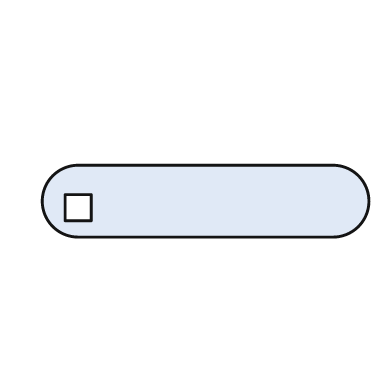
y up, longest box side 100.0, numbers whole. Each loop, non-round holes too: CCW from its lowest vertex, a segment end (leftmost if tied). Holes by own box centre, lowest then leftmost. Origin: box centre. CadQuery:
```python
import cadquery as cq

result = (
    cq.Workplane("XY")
    .moveTo(-39.0, -11.0)
    .lineTo(39.0, -11.0)
    .threePointArc((50.0, 0.0), (39.0, 11.0))
    .lineTo(-39.0, 11.0)
    .threePointArc((-50.0, 0.0), (-39.0, -11.0))
    .close()
    .moveTo(-43.0, -6.0)
    .lineTo(-35.0, -6.0)
    .lineTo(-35.0, 2.0)
    .lineTo(-43.0, 2.0)
    .close()
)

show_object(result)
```